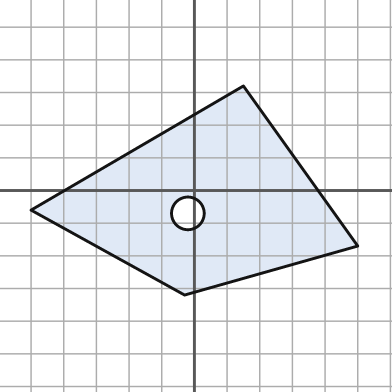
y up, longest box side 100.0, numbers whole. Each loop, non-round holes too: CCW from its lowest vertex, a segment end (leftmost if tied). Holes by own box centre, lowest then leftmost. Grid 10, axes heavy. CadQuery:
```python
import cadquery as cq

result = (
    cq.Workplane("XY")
    .moveTo(-3.0, -32.0)
    .lineTo(50.0, -17.0)
    .lineTo(15.0, 32.0)
    .lineTo(-50.0, -6.0)
    .close()
    .moveTo(-2.0, -7.0)
    .circle(5.0)
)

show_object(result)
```